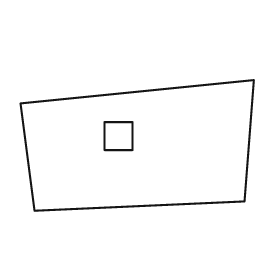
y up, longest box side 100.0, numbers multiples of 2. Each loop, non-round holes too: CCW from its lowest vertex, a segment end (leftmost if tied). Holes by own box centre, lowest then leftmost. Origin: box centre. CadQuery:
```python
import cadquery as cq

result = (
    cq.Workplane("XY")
    .moveTo(-44.0, -28.0)
    .lineTo(46.0, -24.0)
    .lineTo(50.0, 28.0)
    .lineTo(-50.0, 18.0)
    .close()
    .moveTo(-14.0, -2.0)
    .lineTo(-2.0, -2.0)
    .lineTo(-2.0, 10.0)
    .lineTo(-14.0, 10.0)
    .close()
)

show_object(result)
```